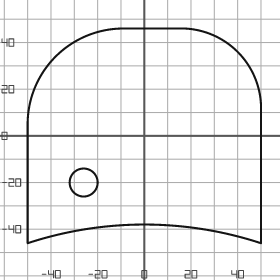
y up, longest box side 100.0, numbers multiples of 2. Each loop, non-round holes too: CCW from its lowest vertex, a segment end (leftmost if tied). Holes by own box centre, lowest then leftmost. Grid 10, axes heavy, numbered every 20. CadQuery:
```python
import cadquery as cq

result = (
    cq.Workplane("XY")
    .moveTo(-50.0, -46.0)
    .threePointArc((0.0, -38.0), (50.0, -46.0))
    .lineTo(50.0, 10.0)
    .threePointArc((40.0, 36.0), (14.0, 46.0))
    .lineTo(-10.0, 46.0)
    .threePointArc((-38.0, 34.0), (-50.0, 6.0))
    .close()
    .moveTo(-26.0, -20.0)
    .circle(6.0)
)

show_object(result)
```